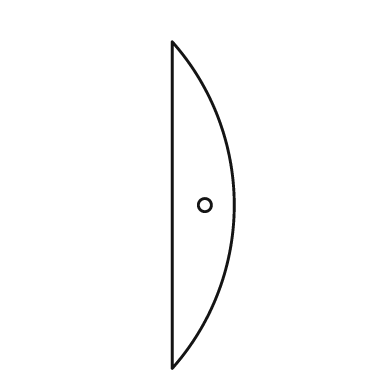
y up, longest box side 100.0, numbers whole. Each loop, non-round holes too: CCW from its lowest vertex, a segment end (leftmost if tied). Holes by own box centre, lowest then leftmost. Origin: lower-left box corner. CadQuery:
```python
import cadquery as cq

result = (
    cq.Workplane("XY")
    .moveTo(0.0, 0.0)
    .threePointArc((19.0, 50.0), (0.0, 100.0))
    .close()
    .moveTo(10.0, 50.0)
    .circle(2.0)
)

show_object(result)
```